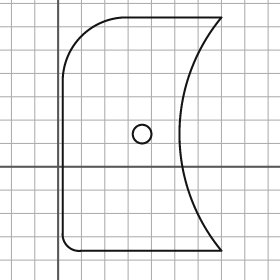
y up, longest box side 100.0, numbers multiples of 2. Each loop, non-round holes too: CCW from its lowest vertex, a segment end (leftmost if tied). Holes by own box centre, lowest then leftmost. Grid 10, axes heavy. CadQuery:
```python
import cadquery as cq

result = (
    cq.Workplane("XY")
    .moveTo(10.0, -36.0)
    .lineTo(70.0, -36.0)
    .threePointArc((52.0, 14.0), (70.0, 64.0))
    .lineTo(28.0, 64.0)
    .threePointArc((10.0, 56.0), (2.0, 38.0))
    .lineTo(2.0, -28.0)
    .threePointArc((4.0, -34.0), (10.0, -36.0))
    .close()
    .moveTo(36.0, 14.0)
    .circle(4.0)
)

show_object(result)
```